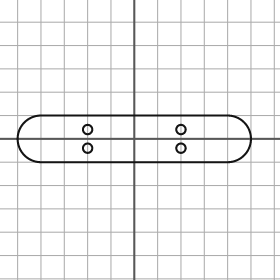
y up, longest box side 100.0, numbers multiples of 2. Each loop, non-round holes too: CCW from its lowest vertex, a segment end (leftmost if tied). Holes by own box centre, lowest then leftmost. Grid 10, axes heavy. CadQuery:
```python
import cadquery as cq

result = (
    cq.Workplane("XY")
    .moveTo(-40.0, -10.0)
    .lineTo(40.0, -10.0)
    .threePointArc((50.0, 0.0), (40.0, 10.0))
    .lineTo(-40.0, 10.0)
    .threePointArc((-50.0, 0.0), (-40.0, -10.0))
    .close()
    .moveTo(-20.0, -4.0)
    .circle(2.0)
    .moveTo(20.0, -4.0)
    .circle(2.0)
    .moveTo(-20.0, 4.0)
    .circle(2.0)
    .moveTo(20.0, 4.0)
    .circle(2.0)
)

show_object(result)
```